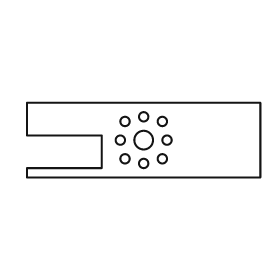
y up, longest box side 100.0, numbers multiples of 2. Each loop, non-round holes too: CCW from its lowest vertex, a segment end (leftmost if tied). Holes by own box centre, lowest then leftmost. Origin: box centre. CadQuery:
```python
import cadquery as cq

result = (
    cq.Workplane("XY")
    .moveTo(-50.0, -16.0)
    .lineTo(50.0, -16.0)
    .lineTo(50.0, 16.0)
    .lineTo(-50.0, 16.0)
    .lineTo(-50.0, 2.0)
    .lineTo(-18.0, 2.0)
    .lineTo(-18.0, -12.0)
    .lineTo(-50.0, -12.0)
    .close()
    .moveTo(0.0, -10.0)
    .circle(2.0)
    .moveTo(-8.0, -8.0)
    .circle(2.0)
    .moveTo(8.0, -8.0)
    .circle(2.0)
    .moveTo(-10.0, 0.0)
    .circle(2.0)
    .moveTo(0.0, 0.0)
    .circle(4.0)
    .moveTo(10.0, 0.0)
    .circle(2.0)
    .moveTo(-8.0, 8.0)
    .circle(2.0)
    .moveTo(8.0, 8.0)
    .circle(2.0)
    .moveTo(0.0, 10.0)
    .circle(2.0)
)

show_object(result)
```